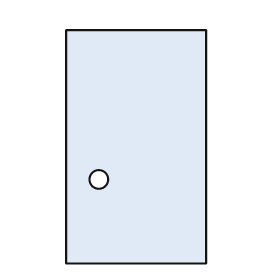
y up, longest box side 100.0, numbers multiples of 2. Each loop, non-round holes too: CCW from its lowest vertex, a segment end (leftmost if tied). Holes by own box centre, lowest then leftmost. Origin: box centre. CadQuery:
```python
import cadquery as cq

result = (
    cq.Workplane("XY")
    .moveTo(-30.0, -50.0)
    .lineTo(30.0, -50.0)
    .lineTo(30.0, 50.0)
    .lineTo(-30.0, 50.0)
    .close()
    .moveTo(-16.0, -14.0)
    .circle(4.0)
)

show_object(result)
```